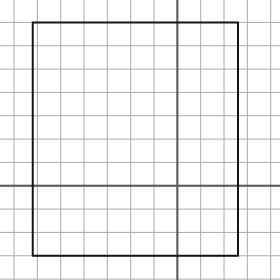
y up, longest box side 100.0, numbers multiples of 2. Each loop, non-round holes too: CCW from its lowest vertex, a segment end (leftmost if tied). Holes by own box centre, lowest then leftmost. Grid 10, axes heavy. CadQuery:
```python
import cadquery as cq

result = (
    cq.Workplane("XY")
    .moveTo(-62.0, -30.0)
    .lineTo(26.0, -30.0)
    .lineTo(26.0, 70.0)
    .lineTo(-62.0, 70.0)
    .close()
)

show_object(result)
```